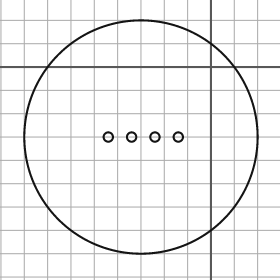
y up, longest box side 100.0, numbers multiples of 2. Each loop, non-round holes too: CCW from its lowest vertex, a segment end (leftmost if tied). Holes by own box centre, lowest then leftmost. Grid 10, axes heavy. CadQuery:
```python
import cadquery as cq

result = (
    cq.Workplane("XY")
    .moveTo(-30.0, -30.0)
    .circle(50.0)
    .moveTo(-44.0, -30.0)
    .circle(2.0)
    .moveTo(-34.0, -30.0)
    .circle(2.0)
    .moveTo(-24.0, -30.0)
    .circle(2.0)
    .moveTo(-14.0, -30.0)
    .circle(2.0)
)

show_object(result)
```